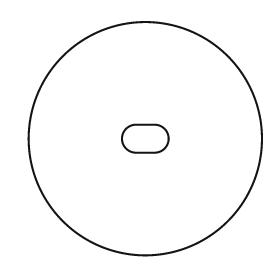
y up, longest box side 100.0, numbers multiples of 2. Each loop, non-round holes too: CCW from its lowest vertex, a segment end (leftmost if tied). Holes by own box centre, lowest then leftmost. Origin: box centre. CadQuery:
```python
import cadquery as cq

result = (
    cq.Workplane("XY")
    .moveTo(0.0, 0.0)
    .circle(50.0)
    .moveTo(-4.0, -6.0)
    .lineTo(4.0, -6.0)
    .threePointArc((10.0, 0.0), (4.0, 6.0))
    .lineTo(-4.0, 6.0)
    .threePointArc((-10.0, 0.0), (-4.0, -6.0))
    .close()
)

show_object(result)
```